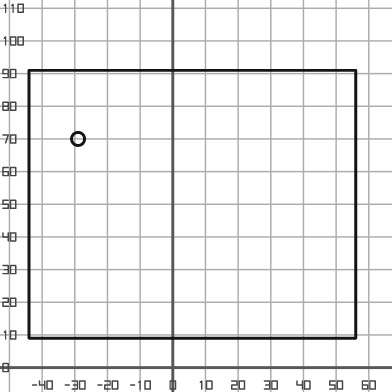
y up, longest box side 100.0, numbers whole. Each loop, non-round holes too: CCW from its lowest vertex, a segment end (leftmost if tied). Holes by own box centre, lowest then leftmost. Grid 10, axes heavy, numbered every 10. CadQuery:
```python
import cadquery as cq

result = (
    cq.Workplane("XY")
    .moveTo(-44.0, 9.0)
    .lineTo(56.0, 9.0)
    .lineTo(56.0, 91.0)
    .lineTo(-44.0, 91.0)
    .close()
    .moveTo(-29.0, 70.0)
    .circle(2.0)
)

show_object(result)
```